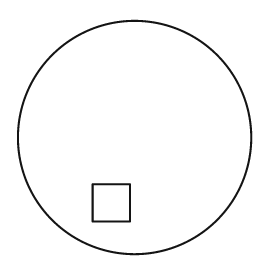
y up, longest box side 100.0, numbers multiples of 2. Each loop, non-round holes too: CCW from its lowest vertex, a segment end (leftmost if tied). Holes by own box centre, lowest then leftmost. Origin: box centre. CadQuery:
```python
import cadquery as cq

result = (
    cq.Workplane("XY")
    .moveTo(0.0, 0.0)
    .circle(50.0)
    .moveTo(-18.0, -36.0)
    .lineTo(-2.0, -36.0)
    .lineTo(-2.0, -20.0)
    .lineTo(-18.0, -20.0)
    .close()
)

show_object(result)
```